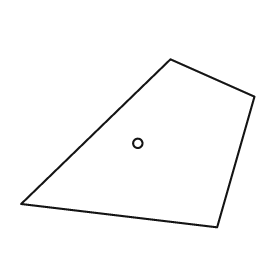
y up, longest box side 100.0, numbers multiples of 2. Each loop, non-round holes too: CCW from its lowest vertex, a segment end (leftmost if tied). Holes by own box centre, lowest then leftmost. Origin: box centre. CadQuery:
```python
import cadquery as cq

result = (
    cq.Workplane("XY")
    .moveTo(34.0, -36.0)
    .lineTo(50.0, 20.0)
    .lineTo(14.0, 36.0)
    .lineTo(-50.0, -26.0)
    .close()
    .moveTo(0.0, 0.0)
    .circle(2.0)
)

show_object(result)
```